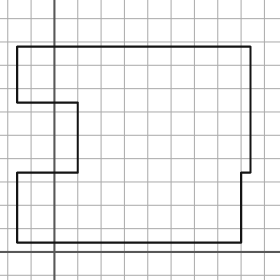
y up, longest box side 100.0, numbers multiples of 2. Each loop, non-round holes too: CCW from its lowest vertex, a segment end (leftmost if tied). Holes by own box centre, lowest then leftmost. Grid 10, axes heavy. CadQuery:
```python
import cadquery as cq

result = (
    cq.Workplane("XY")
    .moveTo(-16.0, 4.0)
    .lineTo(80.0, 4.0)
    .lineTo(80.0, 34.0)
    .lineTo(84.0, 34.0)
    .lineTo(84.0, 88.0)
    .lineTo(-16.0, 88.0)
    .lineTo(-16.0, 64.0)
    .lineTo(10.0, 64.0)
    .lineTo(10.0, 34.0)
    .lineTo(-16.0, 34.0)
    .close()
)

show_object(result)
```